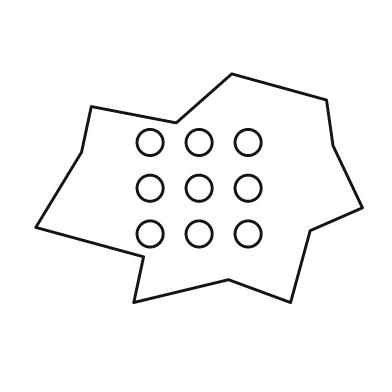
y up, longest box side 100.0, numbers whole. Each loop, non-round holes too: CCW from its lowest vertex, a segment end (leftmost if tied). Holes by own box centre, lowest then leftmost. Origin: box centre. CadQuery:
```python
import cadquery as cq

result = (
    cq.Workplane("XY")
    .moveTo(-20.0, -35.0)
    .lineTo(9.0, -28.0)
    .lineTo(28.0, -35.0)
    .lineTo(34.0, -13.0)
    .lineTo(50.0, -6.0)
    .lineTo(41.0, 13.0)
    .lineTo(39.0, 27.0)
    .lineTo(10.0, 35.0)
    .lineTo(-7.0, 20.0)
    .lineTo(-33.0, 25.0)
    .lineTo(-36.0, 11.0)
    .lineTo(-50.0, -12.0)
    .lineTo(-17.0, -21.0)
    .close()
    .moveTo(-15.0, -14.0)
    .circle(4.0)
    .moveTo(0.0, -14.0)
    .circle(4.0)
    .moveTo(15.0, -14.0)
    .circle(4.0)
    .moveTo(-15.0, 0.0)
    .circle(4.0)
    .moveTo(0.0, 0.0)
    .circle(4.0)
    .moveTo(15.0, 0.0)
    .circle(4.0)
    .moveTo(-15.0, 14.0)
    .circle(4.0)
    .moveTo(0.0, 14.0)
    .circle(4.0)
    .moveTo(15.0, 14.0)
    .circle(4.0)
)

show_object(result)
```